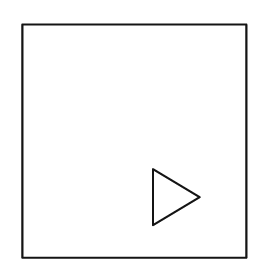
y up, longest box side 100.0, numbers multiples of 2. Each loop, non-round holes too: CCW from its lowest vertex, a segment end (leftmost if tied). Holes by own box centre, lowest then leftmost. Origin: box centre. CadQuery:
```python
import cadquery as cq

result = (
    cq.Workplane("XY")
    .moveTo(-48.0, -50.0)
    .lineTo(48.0, -50.0)
    .lineTo(48.0, 50.0)
    .lineTo(-48.0, 50.0)
    .close()
    .moveTo(8.0, -36.0)
    .lineTo(28.0, -24.0)
    .lineTo(8.0, -12.0)
    .close()
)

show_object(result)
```